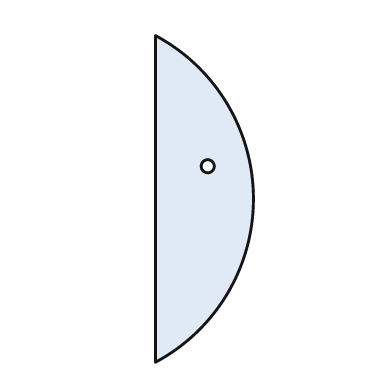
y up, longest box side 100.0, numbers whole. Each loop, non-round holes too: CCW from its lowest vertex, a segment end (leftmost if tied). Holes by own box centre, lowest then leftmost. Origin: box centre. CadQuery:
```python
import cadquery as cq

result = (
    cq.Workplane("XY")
    .moveTo(-15.0, -50.0)
    .threePointArc((15.0, 0.0), (-15.0, 50.0))
    .close()
    .moveTo(1.0, 10.0)
    .circle(2.0)
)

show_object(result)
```